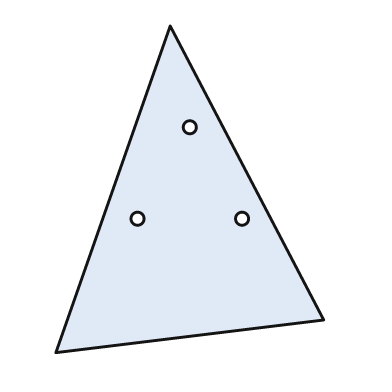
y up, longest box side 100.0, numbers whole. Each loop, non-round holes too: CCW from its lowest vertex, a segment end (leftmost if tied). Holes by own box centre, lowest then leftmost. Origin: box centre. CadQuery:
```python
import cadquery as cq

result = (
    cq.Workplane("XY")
    .moveTo(-41.0, -50.0)
    .lineTo(41.0, -40.0)
    .lineTo(-6.0, 50.0)
    .close()
    .moveTo(-16.0, -9.0)
    .circle(2.0)
    .moveTo(16.0, -9.0)
    .circle(2.0)
    .moveTo(0.0, 19.0)
    .circle(2.0)
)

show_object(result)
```